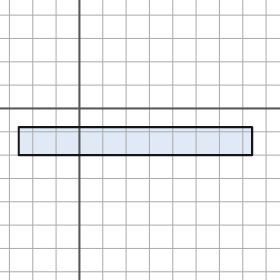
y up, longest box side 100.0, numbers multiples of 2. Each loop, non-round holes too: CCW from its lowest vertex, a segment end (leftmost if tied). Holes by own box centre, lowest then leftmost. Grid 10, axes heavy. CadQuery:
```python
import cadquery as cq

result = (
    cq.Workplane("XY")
    .moveTo(-26.0, -20.0)
    .lineTo(74.0, -20.0)
    .lineTo(74.0, -8.0)
    .lineTo(-26.0, -8.0)
    .close()
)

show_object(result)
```